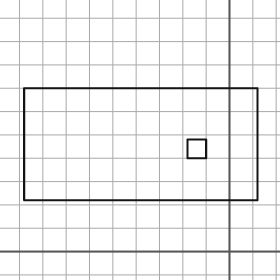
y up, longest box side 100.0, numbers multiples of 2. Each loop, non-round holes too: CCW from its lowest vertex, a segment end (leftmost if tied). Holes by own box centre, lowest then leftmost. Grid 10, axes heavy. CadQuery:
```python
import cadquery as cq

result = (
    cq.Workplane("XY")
    .moveTo(-88.0, 22.0)
    .lineTo(12.0, 22.0)
    .lineTo(12.0, 70.0)
    .lineTo(-88.0, 70.0)
    .close()
    .moveTo(-18.0, 40.0)
    .lineTo(-10.0, 40.0)
    .lineTo(-10.0, 48.0)
    .lineTo(-18.0, 48.0)
    .close()
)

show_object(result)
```